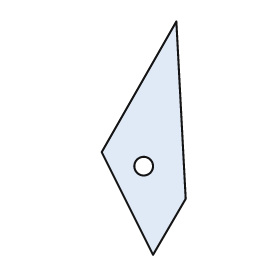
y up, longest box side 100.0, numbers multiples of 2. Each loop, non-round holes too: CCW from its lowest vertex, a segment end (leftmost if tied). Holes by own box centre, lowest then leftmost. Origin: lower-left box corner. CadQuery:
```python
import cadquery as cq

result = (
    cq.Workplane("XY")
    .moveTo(22.0, 0.0)
    .lineTo(36.0, 24.0)
    .lineTo(32.0, 100.0)
    .lineTo(0.0, 44.0)
    .close()
    .moveTo(18.0, 38.0)
    .circle(4.0)
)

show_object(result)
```